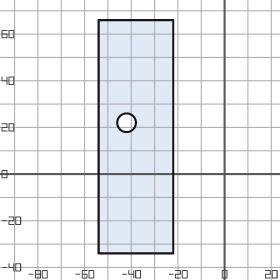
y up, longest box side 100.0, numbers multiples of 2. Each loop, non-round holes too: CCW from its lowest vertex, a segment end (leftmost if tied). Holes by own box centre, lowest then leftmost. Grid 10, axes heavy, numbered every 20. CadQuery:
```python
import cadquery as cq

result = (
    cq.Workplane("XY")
    .moveTo(-54.0, -34.0)
    .lineTo(-22.0, -34.0)
    .lineTo(-22.0, 66.0)
    .lineTo(-54.0, 66.0)
    .close()
    .moveTo(-42.0, 22.0)
    .circle(4.0)
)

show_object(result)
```